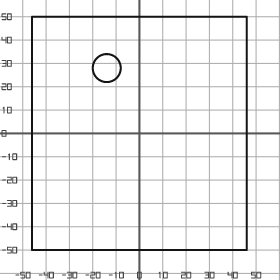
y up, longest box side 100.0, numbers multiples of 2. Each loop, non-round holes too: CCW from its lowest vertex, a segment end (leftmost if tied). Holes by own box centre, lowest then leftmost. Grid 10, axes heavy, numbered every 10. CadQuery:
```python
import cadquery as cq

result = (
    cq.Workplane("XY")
    .moveTo(-46.0, -50.0)
    .lineTo(46.0, -50.0)
    .lineTo(46.0, 50.0)
    .lineTo(-46.0, 50.0)
    .close()
    .moveTo(-14.0, 28.0)
    .circle(6.0)
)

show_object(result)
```